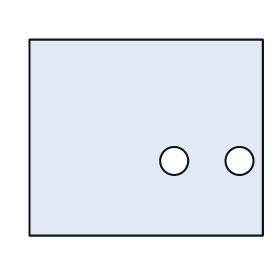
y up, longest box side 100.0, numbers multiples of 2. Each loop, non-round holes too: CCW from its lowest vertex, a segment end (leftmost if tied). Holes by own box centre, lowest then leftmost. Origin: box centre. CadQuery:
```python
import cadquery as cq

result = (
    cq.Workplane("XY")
    .moveTo(-50.0, -42.0)
    .lineTo(50.0, -42.0)
    .lineTo(50.0, 42.0)
    .lineTo(-50.0, 42.0)
    .close()
    .moveTo(12.0, -10.0)
    .circle(6.0)
    .moveTo(40.0, -10.0)
    .circle(6.0)
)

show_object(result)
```